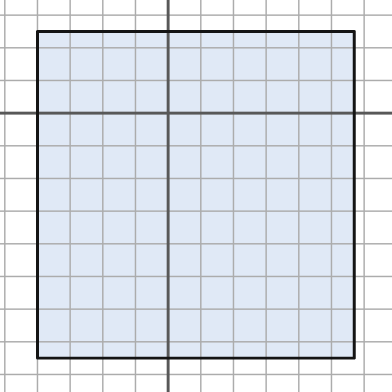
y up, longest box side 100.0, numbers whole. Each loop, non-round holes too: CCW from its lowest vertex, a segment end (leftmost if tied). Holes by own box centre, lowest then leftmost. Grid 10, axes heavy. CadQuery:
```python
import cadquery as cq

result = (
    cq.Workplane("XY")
    .moveTo(-40.0, -75.0)
    .lineTo(57.0, -75.0)
    .lineTo(57.0, 25.0)
    .lineTo(-40.0, 25.0)
    .close()
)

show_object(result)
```